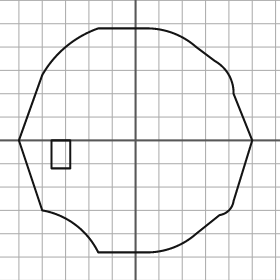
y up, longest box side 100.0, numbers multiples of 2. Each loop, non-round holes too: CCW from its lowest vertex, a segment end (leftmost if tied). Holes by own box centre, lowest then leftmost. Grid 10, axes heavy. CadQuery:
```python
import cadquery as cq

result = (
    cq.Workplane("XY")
    .moveTo(-16.0, -48.0)
    .lineTo(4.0, -48.0)
    .threePointArc((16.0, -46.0), (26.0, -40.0))
    .lineTo(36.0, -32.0)
    .threePointArc((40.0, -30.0), (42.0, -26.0))
    .lineTo(50.0, 0.0)
    .lineTo(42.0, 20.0)
    .threePointArc((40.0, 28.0), (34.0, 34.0))
    .lineTo(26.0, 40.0)
    .threePointArc((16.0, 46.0), (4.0, 48.0))
    .lineTo(-16.0, 48.0)
    .threePointArc((-30.0, 40.0), (-40.0, 28.0))
    .lineTo(-50.0, 0.0)
    .lineTo(-40.0, -30.0)
    .threePointArc((-26.0, -36.0), (-16.0, -48.0))
    .close()
    .moveTo(-36.0, -12.0)
    .lineTo(-28.0, -12.0)
    .lineTo(-28.0, 0.0)
    .lineTo(-36.0, 0.0)
    .close()
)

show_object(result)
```